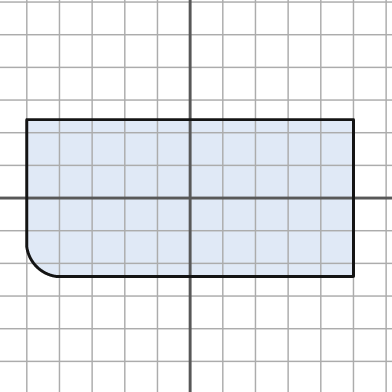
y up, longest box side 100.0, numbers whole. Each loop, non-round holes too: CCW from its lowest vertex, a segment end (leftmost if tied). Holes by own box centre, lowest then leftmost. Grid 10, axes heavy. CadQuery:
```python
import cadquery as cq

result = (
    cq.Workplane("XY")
    .moveTo(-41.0, -24.0)
    .lineTo(50.0, -24.0)
    .lineTo(50.0, 24.0)
    .lineTo(-50.0, 24.0)
    .lineTo(-50.0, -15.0)
    .threePointArc((-47.0, -21.0), (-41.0, -24.0))
    .close()
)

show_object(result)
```